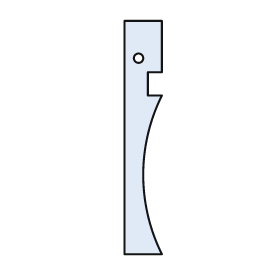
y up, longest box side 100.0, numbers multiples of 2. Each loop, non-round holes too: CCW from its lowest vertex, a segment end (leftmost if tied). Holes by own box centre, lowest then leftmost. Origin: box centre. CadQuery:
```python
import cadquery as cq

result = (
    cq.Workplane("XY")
    .moveTo(-8.0, -50.0)
    .lineTo(8.0, -50.0)
    .threePointArc((0.0, -16.0), (8.0, 18.0))
    .lineTo(2.0, 18.0)
    .lineTo(2.0, 28.0)
    .lineTo(8.0, 28.0)
    .lineTo(8.0, 50.0)
    .lineTo(-8.0, 50.0)
    .close()
    .moveTo(-2.0, 34.0)
    .circle(2.0)
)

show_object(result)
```